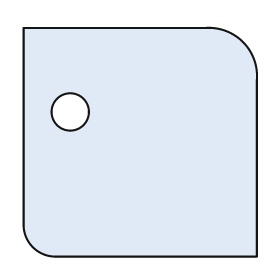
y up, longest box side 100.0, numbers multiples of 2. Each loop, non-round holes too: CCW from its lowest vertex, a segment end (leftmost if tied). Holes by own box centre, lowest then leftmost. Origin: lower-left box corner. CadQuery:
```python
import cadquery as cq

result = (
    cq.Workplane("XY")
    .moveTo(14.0, 0.0)
    .lineTo(100.0, 0.0)
    .lineTo(100.0, 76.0)
    .threePointArc((94.0, 92.0), (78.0, 98.0))
    .lineTo(0.0, 98.0)
    .lineTo(0.0, 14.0)
    .threePointArc((4.0, 4.0), (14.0, 0.0))
    .close()
    .moveTo(20.0, 62.0)
    .circle(8.0)
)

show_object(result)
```